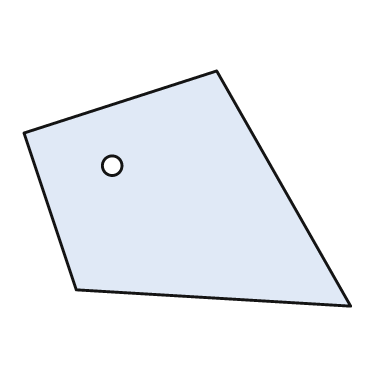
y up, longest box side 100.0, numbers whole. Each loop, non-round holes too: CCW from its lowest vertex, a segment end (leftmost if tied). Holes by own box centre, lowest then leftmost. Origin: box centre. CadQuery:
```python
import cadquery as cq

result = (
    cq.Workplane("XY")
    .moveTo(50.0, -36.0)
    .lineTo(9.0, 36.0)
    .lineTo(-50.0, 17.0)
    .lineTo(-34.0, -31.0)
    .close()
    .moveTo(-23.0, 7.0)
    .circle(3.0)
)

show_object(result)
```